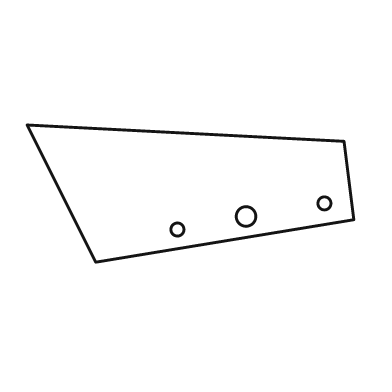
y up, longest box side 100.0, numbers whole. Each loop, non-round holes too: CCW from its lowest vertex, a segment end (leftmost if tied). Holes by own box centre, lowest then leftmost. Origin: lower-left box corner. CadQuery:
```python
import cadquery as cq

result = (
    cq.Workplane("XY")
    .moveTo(21.0, 0.0)
    .lineTo(100.0, 13.0)
    .lineTo(97.0, 37.0)
    .lineTo(0.0, 42.0)
    .close()
    .moveTo(46.0, 10.0)
    .circle(2.0)
    .moveTo(67.0, 14.0)
    .circle(3.0)
    .moveTo(91.0, 18.0)
    .circle(2.0)
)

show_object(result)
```